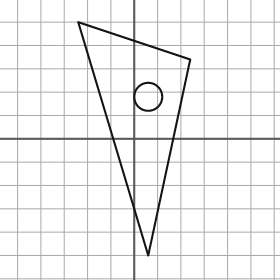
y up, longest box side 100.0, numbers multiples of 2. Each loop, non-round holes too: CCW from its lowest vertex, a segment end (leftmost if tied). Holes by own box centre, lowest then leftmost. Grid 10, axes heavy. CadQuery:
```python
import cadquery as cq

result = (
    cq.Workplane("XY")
    .moveTo(6.0, -50.0)
    .lineTo(24.0, 34.0)
    .lineTo(-24.0, 50.0)
    .close()
    .moveTo(6.0, 18.0)
    .circle(6.0)
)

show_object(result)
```